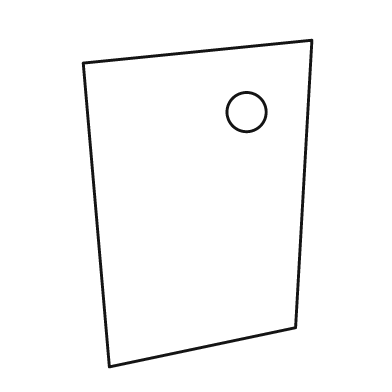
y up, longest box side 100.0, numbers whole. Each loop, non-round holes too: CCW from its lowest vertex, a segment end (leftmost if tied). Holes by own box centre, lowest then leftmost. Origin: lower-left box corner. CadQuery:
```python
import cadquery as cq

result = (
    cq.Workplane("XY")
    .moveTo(8.0, 0.0)
    .lineTo(65.0, 12.0)
    .lineTo(70.0, 100.0)
    .lineTo(0.0, 93.0)
    .close()
    .moveTo(50.0, 78.0)
    .circle(6.0)
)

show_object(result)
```